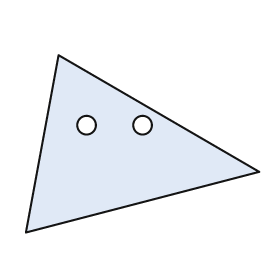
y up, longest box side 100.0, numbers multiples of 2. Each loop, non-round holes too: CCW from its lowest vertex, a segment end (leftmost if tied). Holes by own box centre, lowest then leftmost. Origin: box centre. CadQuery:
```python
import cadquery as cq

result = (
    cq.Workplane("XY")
    .moveTo(-50.0, -38.0)
    .lineTo(50.0, -12.0)
    .lineTo(-36.0, 38.0)
    .close()
    .moveTo(-24.0, 8.0)
    .circle(4.0)
    .moveTo(0.0, 8.0)
    .circle(4.0)
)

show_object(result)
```